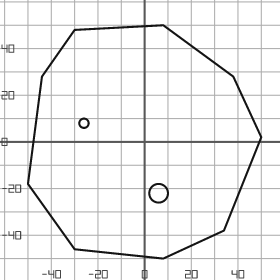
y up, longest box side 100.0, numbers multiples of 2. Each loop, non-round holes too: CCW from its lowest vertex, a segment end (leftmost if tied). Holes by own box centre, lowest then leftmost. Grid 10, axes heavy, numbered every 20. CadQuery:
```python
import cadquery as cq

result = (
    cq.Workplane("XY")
    .moveTo(8.0, -50.0)
    .lineTo(34.0, -38.0)
    .lineTo(50.0, 2.0)
    .lineTo(38.0, 28.0)
    .lineTo(8.0, 50.0)
    .lineTo(-30.0, 48.0)
    .lineTo(-44.0, 28.0)
    .lineTo(-50.0, -18.0)
    .lineTo(-30.0, -46.0)
    .close()
    .moveTo(6.0, -22.0)
    .circle(4.0)
    .moveTo(-26.0, 8.0)
    .circle(2.0)
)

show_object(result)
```